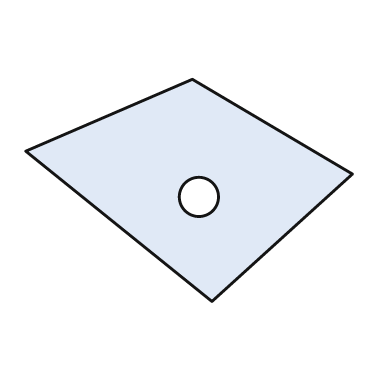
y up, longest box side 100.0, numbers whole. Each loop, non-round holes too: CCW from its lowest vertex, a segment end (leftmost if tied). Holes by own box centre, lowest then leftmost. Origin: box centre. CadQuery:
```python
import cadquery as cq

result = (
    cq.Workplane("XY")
    .moveTo(7.0, -34.0)
    .lineTo(50.0, 5.0)
    .lineTo(1.0, 34.0)
    .lineTo(-50.0, 12.0)
    .close()
    .moveTo(3.0, -2.0)
    .circle(6.0)
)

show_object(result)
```